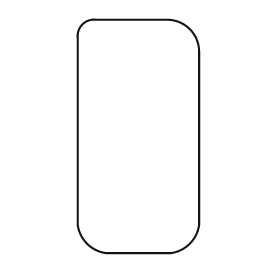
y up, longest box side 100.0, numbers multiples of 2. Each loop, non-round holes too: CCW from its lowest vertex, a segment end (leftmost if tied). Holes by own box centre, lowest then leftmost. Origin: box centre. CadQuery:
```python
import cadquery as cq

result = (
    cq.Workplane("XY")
    .moveTo(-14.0, -50.0)
    .lineTo(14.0, -50.0)
    .threePointArc((22.0, -46.0), (26.0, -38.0))
    .lineTo(26.0, 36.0)
    .threePointArc((22.0, 46.0), (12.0, 50.0))
    .lineTo(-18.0, 50.0)
    .threePointArc((-24.0, 48.0), (-26.0, 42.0))
    .lineTo(-26.0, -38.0)
    .threePointArc((-22.0, -46.0), (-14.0, -50.0))
    .close()
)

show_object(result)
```